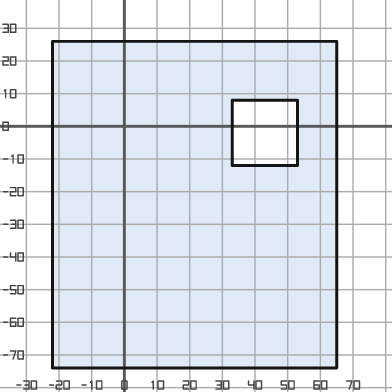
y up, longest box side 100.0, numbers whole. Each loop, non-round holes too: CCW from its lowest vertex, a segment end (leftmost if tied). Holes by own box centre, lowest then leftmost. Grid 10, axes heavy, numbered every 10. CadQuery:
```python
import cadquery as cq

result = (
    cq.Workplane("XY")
    .moveTo(-22.0, -74.0)
    .lineTo(65.0, -74.0)
    .lineTo(65.0, 26.0)
    .lineTo(-22.0, 26.0)
    .close()
    .moveTo(33.0, -12.0)
    .lineTo(53.0, -12.0)
    .lineTo(53.0, 8.0)
    .lineTo(33.0, 8.0)
    .close()
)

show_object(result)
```